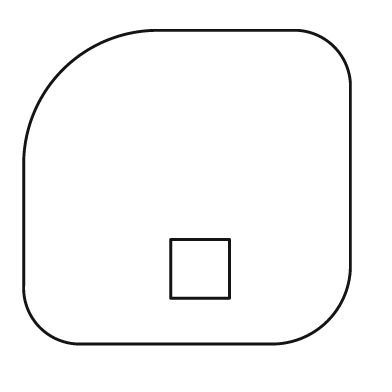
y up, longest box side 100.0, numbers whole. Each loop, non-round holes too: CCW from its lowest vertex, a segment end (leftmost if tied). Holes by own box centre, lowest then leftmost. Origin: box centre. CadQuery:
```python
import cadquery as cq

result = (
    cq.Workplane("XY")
    .moveTo(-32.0, -48.0)
    .lineTo(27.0, -48.0)
    .threePointArc((43.0, -41.0), (50.0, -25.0))
    .lineTo(50.0, 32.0)
    .threePointArc((45.0, 43.0), (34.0, 48.0))
    .lineTo(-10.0, 48.0)
    .threePointArc((-38.0, 36.0), (-50.0, 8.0))
    .lineTo(-50.0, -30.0)
    .threePointArc((-45.0, -43.0), (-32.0, -48.0))
    .close()
    .moveTo(-5.0, -34.0)
    .lineTo(13.0, -34.0)
    .lineTo(13.0, -16.0)
    .lineTo(-5.0, -16.0)
    .close()
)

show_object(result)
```